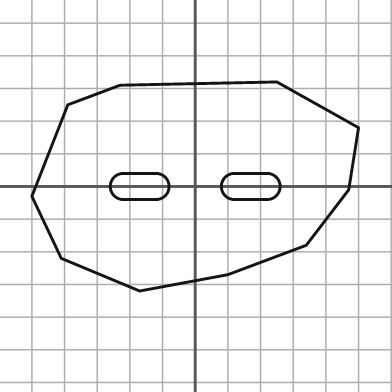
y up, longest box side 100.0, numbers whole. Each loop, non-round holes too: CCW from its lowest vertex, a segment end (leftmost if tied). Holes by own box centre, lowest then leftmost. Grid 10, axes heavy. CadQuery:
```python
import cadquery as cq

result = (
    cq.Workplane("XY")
    .moveTo(-17.0, -32.0)
    .lineTo(10.0, -27.0)
    .lineTo(34.0, -18.0)
    .lineTo(47.0, -1.0)
    .lineTo(50.0, 18.0)
    .lineTo(25.0, 32.0)
    .lineTo(-23.0, 31.0)
    .lineTo(-39.0, 25.0)
    .lineTo(-50.0, -3.0)
    .lineTo(-41.0, -22.0)
    .close()
    .moveTo(-22.0, -4.0)
    .lineTo(-12.0, -4.0)
    .threePointArc((-8.0, 0.0), (-12.0, 4.0))
    .lineTo(-22.0, 4.0)
    .threePointArc((-26.0, 0.0), (-22.0, -4.0))
    .close()
    .moveTo(12.0, -4.0)
    .lineTo(22.0, -4.0)
    .threePointArc((26.0, 0.0), (22.0, 4.0))
    .lineTo(12.0, 4.0)
    .threePointArc((8.0, 0.0), (12.0, -4.0))
    .close()
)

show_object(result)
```